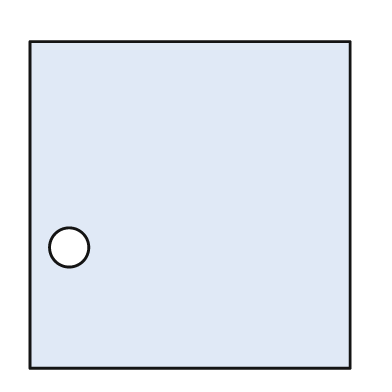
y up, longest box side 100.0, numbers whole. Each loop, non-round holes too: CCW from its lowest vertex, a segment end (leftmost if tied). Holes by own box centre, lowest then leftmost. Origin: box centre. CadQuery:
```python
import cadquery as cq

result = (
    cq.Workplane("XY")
    .moveTo(-49.0, -50.0)
    .lineTo(49.0, -50.0)
    .lineTo(49.0, 50.0)
    .lineTo(-49.0, 50.0)
    .close()
    .moveTo(-37.0, -13.0)
    .circle(6.0)
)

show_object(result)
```